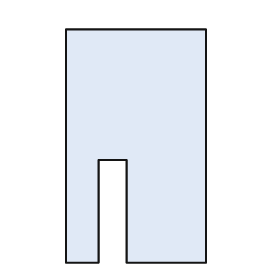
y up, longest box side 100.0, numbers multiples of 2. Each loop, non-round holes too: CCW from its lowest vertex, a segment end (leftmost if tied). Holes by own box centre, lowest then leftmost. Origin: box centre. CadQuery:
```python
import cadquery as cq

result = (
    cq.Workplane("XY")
    .moveTo(-30.0, -50.0)
    .lineTo(-16.0, -50.0)
    .lineTo(-16.0, -6.0)
    .lineTo(-4.0, -6.0)
    .lineTo(-4.0, -50.0)
    .lineTo(30.0, -50.0)
    .lineTo(30.0, 50.0)
    .lineTo(-30.0, 50.0)
    .close()
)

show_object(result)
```